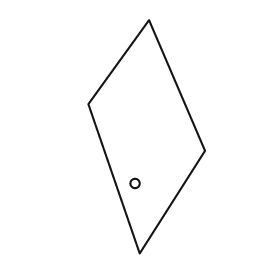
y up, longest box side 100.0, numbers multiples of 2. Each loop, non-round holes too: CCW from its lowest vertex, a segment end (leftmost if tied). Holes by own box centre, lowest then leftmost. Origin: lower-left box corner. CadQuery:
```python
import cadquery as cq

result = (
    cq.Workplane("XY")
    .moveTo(22.0, 0.0)
    .lineTo(50.0, 44.0)
    .lineTo(26.0, 100.0)
    .lineTo(0.0, 64.0)
    .close()
    .moveTo(20.0, 30.0)
    .circle(2.0)
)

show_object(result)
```